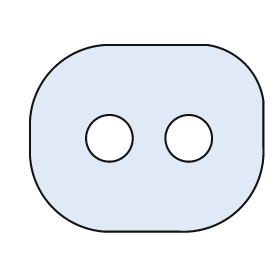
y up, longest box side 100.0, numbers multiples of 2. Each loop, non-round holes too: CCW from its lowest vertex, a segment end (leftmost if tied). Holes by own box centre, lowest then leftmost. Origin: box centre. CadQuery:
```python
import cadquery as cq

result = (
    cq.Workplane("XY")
    .moveTo(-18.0, -40.0)
    .lineTo(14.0, -40.0)
    .threePointArc((40.0, -30.0), (50.0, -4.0))
    .lineTo(50.0, 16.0)
    .threePointArc((42.0, 32.0), (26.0, 40.0))
    .lineTo(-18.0, 40.0)
    .threePointArc((-40.0, 30.0), (-50.0, 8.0))
    .lineTo(-50.0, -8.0)
    .threePointArc((-40.0, -30.0), (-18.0, -40.0))
    .close()
    .moveTo(-16.0, 0.0)
    .circle(10.0)
    .moveTo(18.0, 0.0)
    .circle(10.0)
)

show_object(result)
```